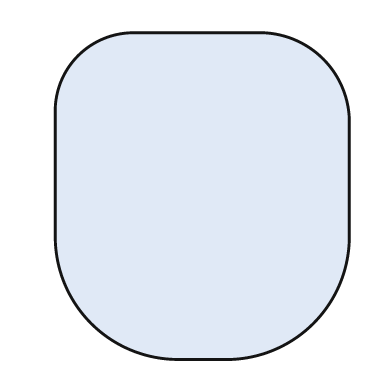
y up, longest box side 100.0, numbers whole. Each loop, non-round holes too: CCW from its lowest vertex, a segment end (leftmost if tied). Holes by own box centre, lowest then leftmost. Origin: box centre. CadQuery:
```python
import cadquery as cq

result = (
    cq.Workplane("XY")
    .moveTo(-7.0, -50.0)
    .lineTo(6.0, -50.0)
    .threePointArc((34.0, -39.0), (45.0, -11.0))
    .lineTo(45.0, 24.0)
    .threePointArc((37.0, 42.0), (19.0, 50.0))
    .lineTo(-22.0, 50.0)
    .threePointArc((-38.0, 43.0), (-45.0, 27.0))
    .lineTo(-45.0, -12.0)
    .threePointArc((-34.0, -39.0), (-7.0, -50.0))
    .close()
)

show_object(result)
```